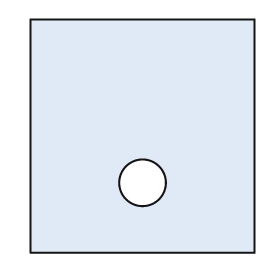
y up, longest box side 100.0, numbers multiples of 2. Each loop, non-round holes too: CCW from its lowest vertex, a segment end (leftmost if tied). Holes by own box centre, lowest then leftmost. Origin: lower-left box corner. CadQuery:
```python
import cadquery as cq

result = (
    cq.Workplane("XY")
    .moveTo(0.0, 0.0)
    .lineTo(96.0, 0.0)
    .lineTo(96.0, 100.0)
    .lineTo(0.0, 100.0)
    .close()
    .moveTo(48.0, 30.0)
    .circle(10.0)
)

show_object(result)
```